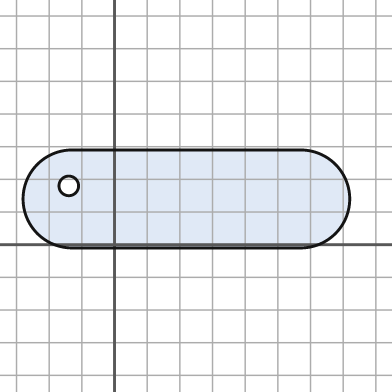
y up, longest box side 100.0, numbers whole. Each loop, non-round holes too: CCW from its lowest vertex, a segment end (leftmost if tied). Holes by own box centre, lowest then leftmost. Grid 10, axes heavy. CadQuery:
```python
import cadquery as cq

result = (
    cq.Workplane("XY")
    .moveTo(-13.0, -1.0)
    .lineTo(57.0, -1.0)
    .threePointArc((72.0, 14.0), (57.0, 29.0))
    .lineTo(-13.0, 29.0)
    .threePointArc((-28.0, 14.0), (-13.0, -1.0))
    .close()
    .moveTo(-14.0, 18.0)
    .circle(3.0)
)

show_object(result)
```